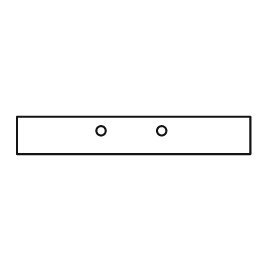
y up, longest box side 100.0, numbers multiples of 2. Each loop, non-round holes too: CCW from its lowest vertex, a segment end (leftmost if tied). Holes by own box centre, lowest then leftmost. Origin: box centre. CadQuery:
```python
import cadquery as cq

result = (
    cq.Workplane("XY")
    .moveTo(-50.0, -8.0)
    .lineTo(50.0, -8.0)
    .lineTo(50.0, 8.0)
    .lineTo(-50.0, 8.0)
    .close()
    .moveTo(-14.0, 2.0)
    .circle(2.0)
    .moveTo(12.0, 2.0)
    .circle(2.0)
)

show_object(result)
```